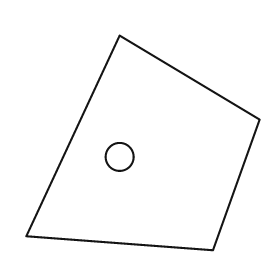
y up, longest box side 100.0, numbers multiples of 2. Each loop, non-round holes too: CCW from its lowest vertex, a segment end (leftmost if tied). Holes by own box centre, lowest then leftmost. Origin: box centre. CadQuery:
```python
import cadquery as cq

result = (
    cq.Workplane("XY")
    .moveTo(30.0, -46.0)
    .lineTo(50.0, 10.0)
    .lineTo(-10.0, 46.0)
    .lineTo(-50.0, -40.0)
    .close()
    .moveTo(-10.0, -6.0)
    .circle(6.0)
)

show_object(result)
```